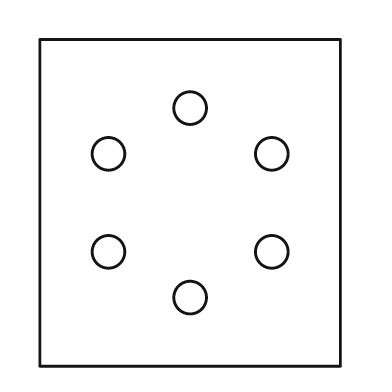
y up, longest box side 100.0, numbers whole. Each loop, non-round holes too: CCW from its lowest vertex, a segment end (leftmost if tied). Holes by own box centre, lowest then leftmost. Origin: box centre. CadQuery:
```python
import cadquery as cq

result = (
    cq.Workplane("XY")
    .moveTo(-46.0, -50.0)
    .lineTo(46.0, -50.0)
    .lineTo(46.0, 50.0)
    .lineTo(-46.0, 50.0)
    .close()
    .moveTo(0.0, -29.0)
    .circle(5.0)
    .moveTo(-25.0, -15.0)
    .circle(5.0)
    .moveTo(25.0, -15.0)
    .circle(5.0)
    .moveTo(-25.0, 15.0)
    .circle(5.0)
    .moveTo(25.0, 15.0)
    .circle(5.0)
    .moveTo(0.0, 29.0)
    .circle(5.0)
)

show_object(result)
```